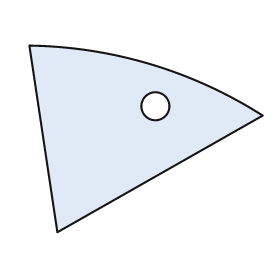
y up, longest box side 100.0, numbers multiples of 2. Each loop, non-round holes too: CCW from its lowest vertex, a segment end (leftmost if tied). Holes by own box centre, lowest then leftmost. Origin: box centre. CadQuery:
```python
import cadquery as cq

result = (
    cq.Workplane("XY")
    .moveTo(-38.0, -40.0)
    .lineTo(50.0, 10.0)
    .threePointArc((2.0, 32.0), (-50.0, 40.0))
    .close()
    .moveTo(4.0, 14.0)
    .circle(6.0)
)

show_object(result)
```